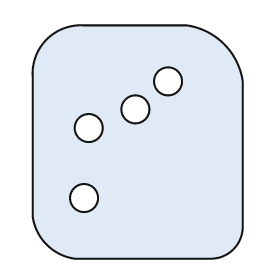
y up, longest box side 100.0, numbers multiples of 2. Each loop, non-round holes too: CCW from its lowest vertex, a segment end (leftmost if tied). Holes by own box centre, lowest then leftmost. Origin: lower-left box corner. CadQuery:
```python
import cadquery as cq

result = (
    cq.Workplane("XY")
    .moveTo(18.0, 0.0)
    .lineTo(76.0, 0.0)
    .threePointArc((86.0, 4.0), (90.0, 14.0))
    .lineTo(90.0, 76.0)
    .threePointArc((82.0, 92.0), (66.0, 100.0))
    .lineTo(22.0, 100.0)
    .threePointArc((6.0, 94.0), (0.0, 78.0))
    .lineTo(0.0, 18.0)
    .threePointArc((6.0, 6.0), (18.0, 0.0))
    .close()
    .moveTo(22.0, 26.0)
    .circle(6.0)
    .moveTo(24.0, 56.0)
    .circle(6.0)
    .moveTo(44.0, 64.0)
    .circle(6.0)
    .moveTo(58.0, 76.0)
    .circle(6.0)
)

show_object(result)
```